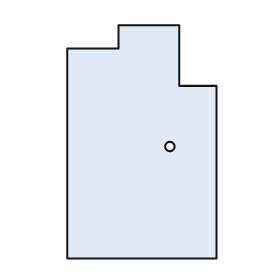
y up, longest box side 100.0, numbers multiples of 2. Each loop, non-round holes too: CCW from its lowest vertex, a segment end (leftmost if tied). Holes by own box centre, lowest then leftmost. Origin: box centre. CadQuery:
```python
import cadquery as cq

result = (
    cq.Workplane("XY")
    .moveTo(-32.0, -50.0)
    .lineTo(32.0, -50.0)
    .lineTo(32.0, 24.0)
    .lineTo(16.0, 24.0)
    .lineTo(16.0, 50.0)
    .lineTo(-10.0, 50.0)
    .lineTo(-10.0, 40.0)
    .lineTo(-32.0, 40.0)
    .close()
    .moveTo(12.0, -2.0)
    .circle(2.0)
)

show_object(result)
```